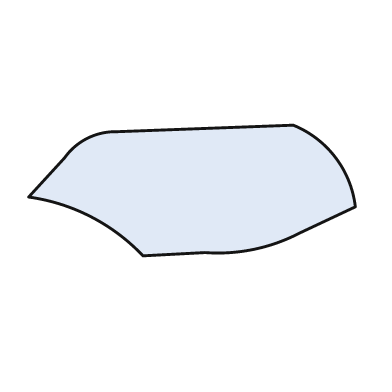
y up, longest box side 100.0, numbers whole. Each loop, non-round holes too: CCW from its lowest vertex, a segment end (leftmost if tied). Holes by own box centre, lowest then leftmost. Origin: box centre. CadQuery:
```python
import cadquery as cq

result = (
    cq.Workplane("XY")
    .moveTo(-15.0, -20.0)
    .lineTo(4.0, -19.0)
    .threePointArc((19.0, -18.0), (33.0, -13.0))
    .lineTo(50.0, -5.0)
    .threePointArc((44.0, 10.0), (31.0, 20.0))
    .lineTo(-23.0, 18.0)
    .threePointArc((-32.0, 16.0), (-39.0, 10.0))
    .lineTo(-50.0, -2.0)
    .threePointArc((-31.0, -8.0), (-15.0, -20.0))
    .close()
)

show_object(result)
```